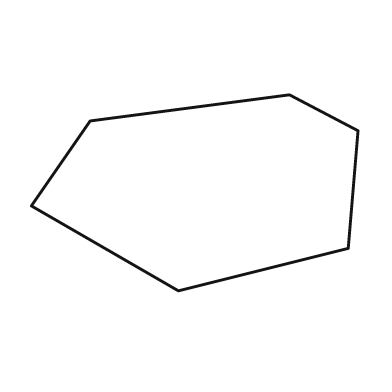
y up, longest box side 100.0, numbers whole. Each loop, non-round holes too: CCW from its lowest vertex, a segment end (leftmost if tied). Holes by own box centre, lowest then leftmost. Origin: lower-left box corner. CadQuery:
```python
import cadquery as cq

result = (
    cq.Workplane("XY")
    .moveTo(45.0, 0.0)
    .lineTo(97.0, 13.0)
    .lineTo(100.0, 49.0)
    .lineTo(79.0, 60.0)
    .lineTo(18.0, 52.0)
    .lineTo(0.0, 26.0)
    .close()
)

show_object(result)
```